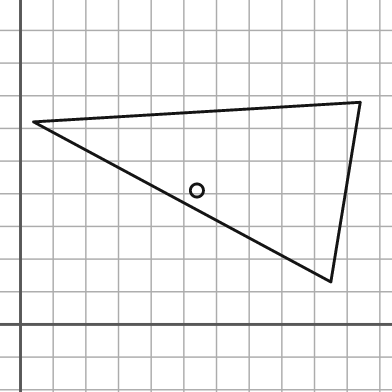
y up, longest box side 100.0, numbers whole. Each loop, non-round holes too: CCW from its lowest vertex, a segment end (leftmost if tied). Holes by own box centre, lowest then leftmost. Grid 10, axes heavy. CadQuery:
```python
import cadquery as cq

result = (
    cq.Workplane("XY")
    .moveTo(95.0, 13.0)
    .lineTo(104.0, 68.0)
    .lineTo(4.0, 62.0)
    .close()
    .moveTo(54.0, 41.0)
    .circle(2.0)
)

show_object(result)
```